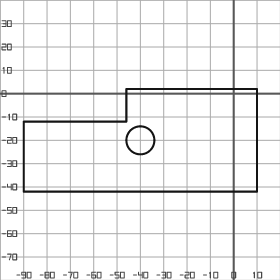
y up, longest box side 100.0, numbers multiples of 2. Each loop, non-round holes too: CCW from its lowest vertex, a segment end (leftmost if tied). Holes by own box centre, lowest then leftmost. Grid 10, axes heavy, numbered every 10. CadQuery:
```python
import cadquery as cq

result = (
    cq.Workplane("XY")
    .moveTo(-90.0, -42.0)
    .lineTo(10.0, -42.0)
    .lineTo(10.0, 2.0)
    .lineTo(-46.0, 2.0)
    .lineTo(-46.0, -12.0)
    .lineTo(-90.0, -12.0)
    .close()
    .moveTo(-40.0, -20.0)
    .circle(6.0)
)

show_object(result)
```